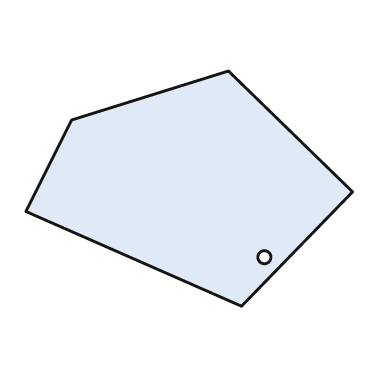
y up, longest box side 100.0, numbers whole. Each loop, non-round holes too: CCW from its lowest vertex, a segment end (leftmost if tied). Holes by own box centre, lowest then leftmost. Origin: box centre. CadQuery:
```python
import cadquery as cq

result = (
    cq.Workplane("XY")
    .moveTo(16.0, -36.0)
    .lineTo(50.0, -1.0)
    .lineTo(12.0, 36.0)
    .lineTo(-36.0, 21.0)
    .lineTo(-50.0, -7.0)
    .close()
    .moveTo(23.0, -21.0)
    .circle(2.0)
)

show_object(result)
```